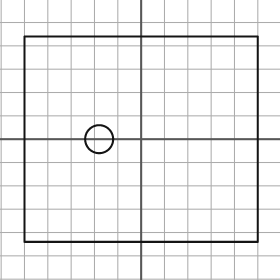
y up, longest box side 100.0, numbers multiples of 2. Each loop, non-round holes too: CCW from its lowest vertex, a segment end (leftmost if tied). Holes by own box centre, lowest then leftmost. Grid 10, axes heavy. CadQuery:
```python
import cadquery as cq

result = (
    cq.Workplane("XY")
    .moveTo(-50.0, -44.0)
    .lineTo(50.0, -44.0)
    .lineTo(50.0, 44.0)
    .lineTo(-50.0, 44.0)
    .close()
    .moveTo(-18.0, 0.0)
    .circle(6.0)
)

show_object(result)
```